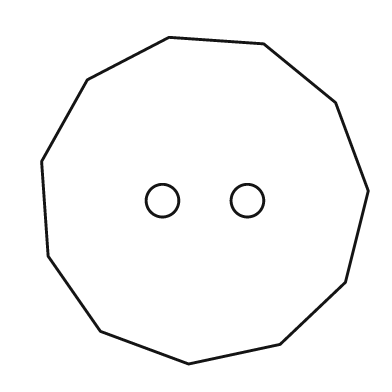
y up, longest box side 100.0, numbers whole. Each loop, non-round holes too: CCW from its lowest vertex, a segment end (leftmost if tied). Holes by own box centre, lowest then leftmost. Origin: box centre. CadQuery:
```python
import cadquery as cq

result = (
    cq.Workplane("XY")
    .moveTo(-5.0, -50.0)
    .lineTo(23.0, -44.0)
    .lineTo(43.0, -25.0)
    .lineTo(50.0, 3.0)
    .lineTo(40.0, 30.0)
    .lineTo(18.0, 48.0)
    .lineTo(-11.0, 50.0)
    .lineTo(-36.0, 37.0)
    .lineTo(-50.0, 12.0)
    .lineTo(-48.0, -17.0)
    .lineTo(-32.0, -40.0)
    .close()
    .moveTo(-13.0, 0.0)
    .circle(5.0)
    .moveTo(13.0, 0.0)
    .circle(5.0)
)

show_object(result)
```